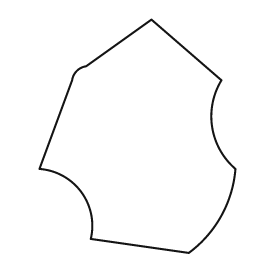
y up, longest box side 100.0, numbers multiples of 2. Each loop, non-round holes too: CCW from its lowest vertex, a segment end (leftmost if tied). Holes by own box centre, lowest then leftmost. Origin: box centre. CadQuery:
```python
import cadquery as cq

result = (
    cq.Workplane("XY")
    .moveTo(22.0, -50.0)
    .threePointArc((36.0, -34.0), (42.0, -14.0))
    .threePointArc((32.0, 4.0), (36.0, 24.0))
    .lineTo(6.0, 50.0)
    .lineTo(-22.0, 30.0)
    .threePointArc((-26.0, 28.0), (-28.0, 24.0))
    .lineTo(-42.0, -14.0)
    .threePointArc((-24.0, -24.0), (-20.0, -44.0))
    .close()
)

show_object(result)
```